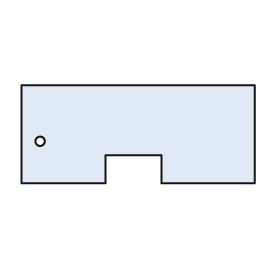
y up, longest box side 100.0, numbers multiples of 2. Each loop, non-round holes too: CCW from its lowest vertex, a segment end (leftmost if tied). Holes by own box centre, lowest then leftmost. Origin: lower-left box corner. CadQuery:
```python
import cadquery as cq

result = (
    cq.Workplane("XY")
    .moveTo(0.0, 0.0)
    .lineTo(36.0, 0.0)
    .lineTo(36.0, 12.0)
    .lineTo(60.0, 12.0)
    .lineTo(60.0, 0.0)
    .lineTo(100.0, 0.0)
    .lineTo(100.0, 42.0)
    .lineTo(0.0, 42.0)
    .close()
    .moveTo(8.0, 18.0)
    .circle(2.0)
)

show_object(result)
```